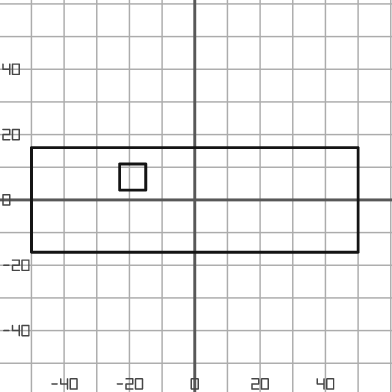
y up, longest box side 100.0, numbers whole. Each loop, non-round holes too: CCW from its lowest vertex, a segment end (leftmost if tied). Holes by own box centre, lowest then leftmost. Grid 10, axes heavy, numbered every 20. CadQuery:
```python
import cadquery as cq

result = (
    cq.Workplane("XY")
    .moveTo(-50.0, -16.0)
    .lineTo(50.0, -16.0)
    .lineTo(50.0, 16.0)
    .lineTo(-50.0, 16.0)
    .close()
    .moveTo(-23.0, 3.0)
    .lineTo(-15.0, 3.0)
    .lineTo(-15.0, 11.0)
    .lineTo(-23.0, 11.0)
    .close()
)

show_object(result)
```